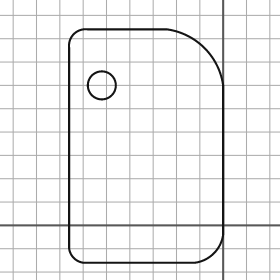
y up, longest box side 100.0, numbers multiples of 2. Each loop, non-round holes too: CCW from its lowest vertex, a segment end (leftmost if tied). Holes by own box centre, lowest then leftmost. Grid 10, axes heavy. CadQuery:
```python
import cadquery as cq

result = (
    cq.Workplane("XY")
    .moveTo(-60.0, -16.0)
    .lineTo(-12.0, -16.0)
    .threePointArc((-4.0, -12.0), (0.0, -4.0))
    .lineTo(0.0, 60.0)
    .threePointArc((-8.0, 76.0), (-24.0, 84.0))
    .lineTo(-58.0, 84.0)
    .threePointArc((-64.0, 82.0), (-66.0, 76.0))
    .lineTo(-66.0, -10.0)
    .threePointArc((-64.0, -14.0), (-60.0, -16.0))
    .close()
    .moveTo(-52.0, 60.0)
    .circle(6.0)
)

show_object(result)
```